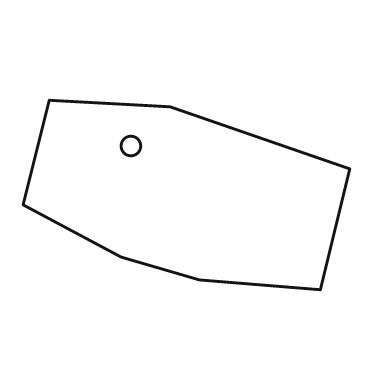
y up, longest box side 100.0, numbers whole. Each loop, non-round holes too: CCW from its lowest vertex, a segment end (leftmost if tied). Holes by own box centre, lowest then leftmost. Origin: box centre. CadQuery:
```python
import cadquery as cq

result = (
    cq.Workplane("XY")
    .moveTo(41.0, -29.0)
    .lineTo(50.0, 8.0)
    .lineTo(-5.0, 27.0)
    .lineTo(-42.0, 29.0)
    .lineTo(-50.0, -3.0)
    .lineTo(-20.0, -19.0)
    .lineTo(4.0, -26.0)
    .close()
    .moveTo(-17.0, 15.0)
    .circle(3.0)
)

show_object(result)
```